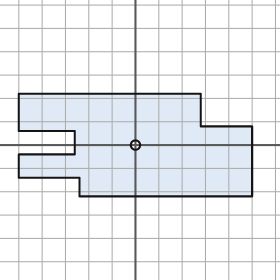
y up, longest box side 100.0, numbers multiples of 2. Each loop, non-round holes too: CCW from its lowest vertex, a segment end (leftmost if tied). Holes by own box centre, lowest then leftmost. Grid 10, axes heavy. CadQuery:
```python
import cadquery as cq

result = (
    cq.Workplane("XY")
    .moveTo(-24.0, -22.0)
    .lineTo(50.0, -22.0)
    .lineTo(50.0, 8.0)
    .lineTo(28.0, 8.0)
    .lineTo(28.0, 22.0)
    .lineTo(-50.0, 22.0)
    .lineTo(-50.0, 6.0)
    .lineTo(-26.0, 6.0)
    .lineTo(-26.0, -4.0)
    .lineTo(-50.0, -4.0)
    .lineTo(-50.0, -14.0)
    .lineTo(-24.0, -14.0)
    .close()
    .moveTo(0.0, 0.0)
    .circle(2.0)
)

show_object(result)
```